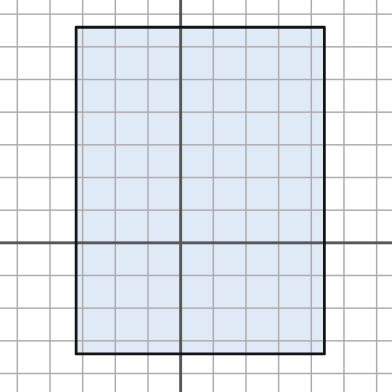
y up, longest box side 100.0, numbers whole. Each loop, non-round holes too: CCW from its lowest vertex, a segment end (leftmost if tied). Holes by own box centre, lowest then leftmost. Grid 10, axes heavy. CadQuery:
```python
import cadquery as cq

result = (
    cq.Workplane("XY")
    .moveTo(-32.0, -34.0)
    .lineTo(44.0, -34.0)
    .lineTo(44.0, 66.0)
    .lineTo(-32.0, 66.0)
    .close()
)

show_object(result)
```